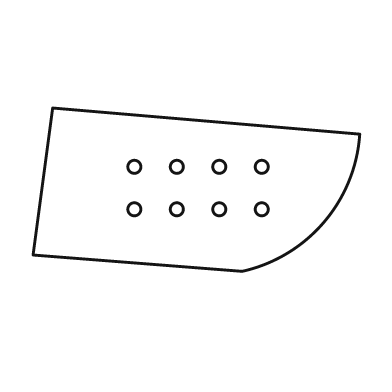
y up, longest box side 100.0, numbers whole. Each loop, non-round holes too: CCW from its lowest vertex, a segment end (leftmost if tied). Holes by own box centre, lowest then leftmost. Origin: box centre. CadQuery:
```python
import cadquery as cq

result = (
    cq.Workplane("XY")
    .moveTo(14.0, -25.0)
    .threePointArc((39.0, -10.0), (50.0, 17.0))
    .lineTo(-44.0, 25.0)
    .lineTo(-50.0, -20.0)
    .close()
    .moveTo(-19.0, -6.0)
    .circle(2.0)
    .moveTo(-6.0, -6.0)
    .circle(2.0)
    .moveTo(7.0, -6.0)
    .circle(2.0)
    .moveTo(20.0, -6.0)
    .circle(2.0)
    .moveTo(-19.0, 7.0)
    .circle(2.0)
    .moveTo(-6.0, 7.0)
    .circle(2.0)
    .moveTo(7.0, 7.0)
    .circle(2.0)
    .moveTo(20.0, 7.0)
    .circle(2.0)
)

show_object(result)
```